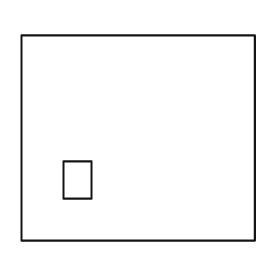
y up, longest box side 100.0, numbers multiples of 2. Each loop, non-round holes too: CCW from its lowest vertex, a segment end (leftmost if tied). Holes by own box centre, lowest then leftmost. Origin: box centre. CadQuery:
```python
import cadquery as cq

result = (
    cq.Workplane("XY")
    .moveTo(-50.0, -44.0)
    .lineTo(50.0, -44.0)
    .lineTo(50.0, 44.0)
    .lineTo(-50.0, 44.0)
    .close()
    .moveTo(-32.0, -26.0)
    .lineTo(-20.0, -26.0)
    .lineTo(-20.0, -10.0)
    .lineTo(-32.0, -10.0)
    .close()
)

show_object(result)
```